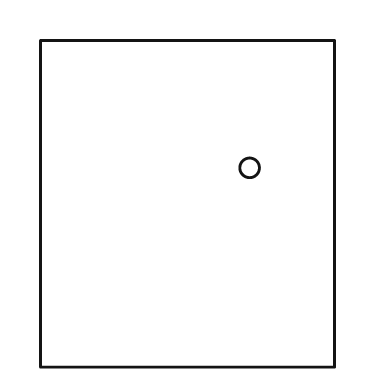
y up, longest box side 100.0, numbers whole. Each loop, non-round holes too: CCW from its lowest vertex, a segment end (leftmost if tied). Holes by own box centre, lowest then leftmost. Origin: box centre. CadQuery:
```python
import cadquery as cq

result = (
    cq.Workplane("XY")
    .moveTo(-45.0, -50.0)
    .lineTo(45.0, -50.0)
    .lineTo(45.0, 50.0)
    .lineTo(-45.0, 50.0)
    .close()
    .moveTo(19.0, 11.0)
    .circle(3.0)
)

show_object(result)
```